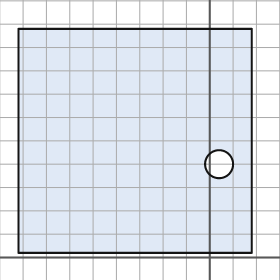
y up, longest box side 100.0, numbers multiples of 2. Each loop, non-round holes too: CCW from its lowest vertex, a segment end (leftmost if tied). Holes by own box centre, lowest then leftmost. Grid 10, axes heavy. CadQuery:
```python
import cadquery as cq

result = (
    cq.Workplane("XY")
    .moveTo(-82.0, 2.0)
    .lineTo(18.0, 2.0)
    .lineTo(18.0, 98.0)
    .lineTo(-82.0, 98.0)
    .close()
    .moveTo(4.0, 40.0)
    .circle(6.0)
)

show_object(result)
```